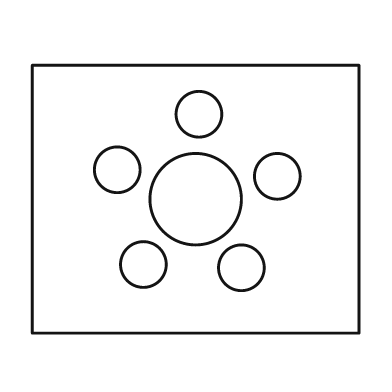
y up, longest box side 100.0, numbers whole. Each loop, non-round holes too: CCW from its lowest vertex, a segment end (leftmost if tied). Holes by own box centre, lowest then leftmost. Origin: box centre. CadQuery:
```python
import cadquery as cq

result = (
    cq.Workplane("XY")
    .moveTo(-50.0, -41.0)
    .lineTo(50.0, -41.0)
    .lineTo(50.0, 41.0)
    .lineTo(-50.0, 41.0)
    .close()
    .moveTo(14.0, -21.0)
    .circle(7.0)
    .moveTo(-16.0, -20.0)
    .circle(7.0)
    .moveTo(0.0, 0.0)
    .circle(14.0)
    .moveTo(25.0, 7.0)
    .circle(7.0)
    .moveTo(-24.0, 9.0)
    .circle(7.0)
    .moveTo(1.0, 26.0)
    .circle(7.0)
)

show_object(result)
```